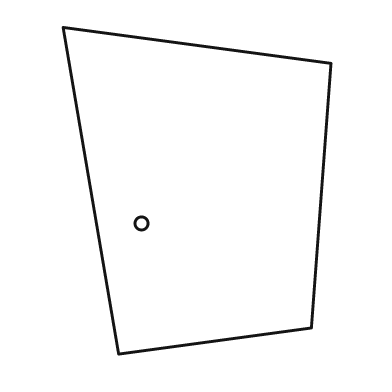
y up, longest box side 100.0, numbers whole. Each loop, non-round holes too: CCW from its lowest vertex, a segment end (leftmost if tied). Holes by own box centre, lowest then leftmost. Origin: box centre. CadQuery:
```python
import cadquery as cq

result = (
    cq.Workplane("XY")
    .moveTo(-24.0, -50.0)
    .lineTo(35.0, -42.0)
    .lineTo(41.0, 39.0)
    .lineTo(-41.0, 50.0)
    .close()
    .moveTo(-17.0, -10.0)
    .circle(2.0)
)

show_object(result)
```